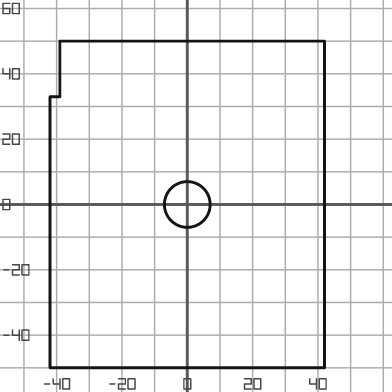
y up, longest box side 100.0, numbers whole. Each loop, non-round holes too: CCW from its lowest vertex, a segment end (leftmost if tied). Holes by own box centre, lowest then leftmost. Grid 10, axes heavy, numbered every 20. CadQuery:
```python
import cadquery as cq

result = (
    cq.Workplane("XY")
    .moveTo(-42.0, -50.0)
    .lineTo(42.0, -50.0)
    .lineTo(42.0, 50.0)
    .lineTo(-39.0, 50.0)
    .lineTo(-39.0, 33.0)
    .lineTo(-42.0, 33.0)
    .close()
    .moveTo(0.0, 0.0)
    .circle(7.0)
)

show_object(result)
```